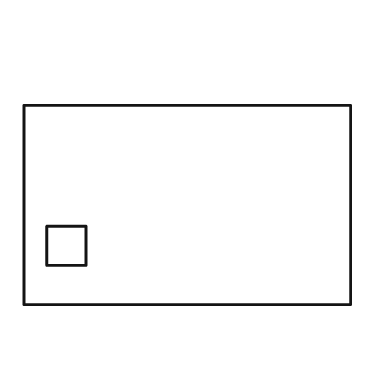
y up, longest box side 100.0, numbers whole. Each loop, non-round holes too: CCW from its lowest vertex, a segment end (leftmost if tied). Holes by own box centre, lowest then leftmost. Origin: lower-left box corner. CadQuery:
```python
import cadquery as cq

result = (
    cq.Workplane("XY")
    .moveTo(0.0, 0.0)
    .lineTo(100.0, 0.0)
    .lineTo(100.0, 61.0)
    .lineTo(0.0, 61.0)
    .close()
    .moveTo(7.0, 12.0)
    .lineTo(19.0, 12.0)
    .lineTo(19.0, 24.0)
    .lineTo(7.0, 24.0)
    .close()
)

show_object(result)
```